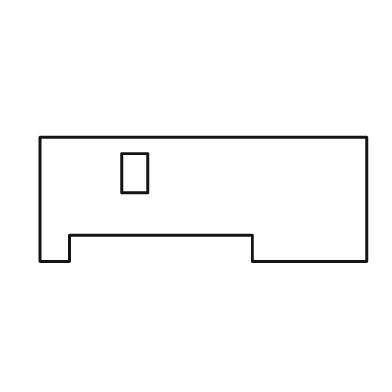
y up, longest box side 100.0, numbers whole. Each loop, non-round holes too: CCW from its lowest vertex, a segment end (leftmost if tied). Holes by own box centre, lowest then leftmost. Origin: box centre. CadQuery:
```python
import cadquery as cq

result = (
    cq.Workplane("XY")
    .moveTo(-50.0, -19.0)
    .lineTo(-41.0, -19.0)
    .lineTo(-41.0, -11.0)
    .lineTo(15.0, -11.0)
    .lineTo(15.0, -19.0)
    .lineTo(50.0, -19.0)
    .lineTo(50.0, 19.0)
    .lineTo(-50.0, 19.0)
    .close()
    .moveTo(-25.0, 2.0)
    .lineTo(-17.0, 2.0)
    .lineTo(-17.0, 14.0)
    .lineTo(-25.0, 14.0)
    .close()
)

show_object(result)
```